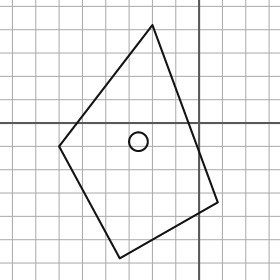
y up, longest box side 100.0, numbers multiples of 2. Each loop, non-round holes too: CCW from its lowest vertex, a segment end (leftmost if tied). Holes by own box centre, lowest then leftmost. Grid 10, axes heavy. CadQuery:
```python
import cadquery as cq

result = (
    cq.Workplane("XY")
    .moveTo(-34.0, -58.0)
    .lineTo(8.0, -34.0)
    .lineTo(-20.0, 42.0)
    .lineTo(-60.0, -10.0)
    .close()
    .moveTo(-26.0, -8.0)
    .circle(4.0)
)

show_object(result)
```